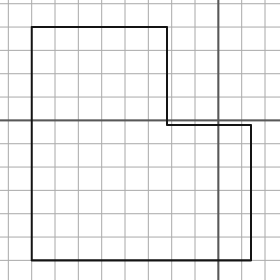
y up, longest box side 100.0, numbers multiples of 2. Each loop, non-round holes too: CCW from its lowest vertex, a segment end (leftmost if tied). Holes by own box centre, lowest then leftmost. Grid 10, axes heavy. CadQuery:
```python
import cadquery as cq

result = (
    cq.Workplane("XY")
    .moveTo(-80.0, -60.0)
    .lineTo(14.0, -60.0)
    .lineTo(14.0, -2.0)
    .lineTo(-22.0, -2.0)
    .lineTo(-22.0, 40.0)
    .lineTo(-80.0, 40.0)
    .close()
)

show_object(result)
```